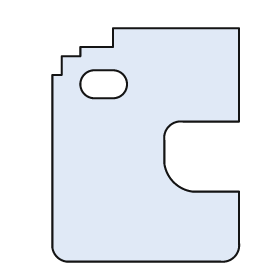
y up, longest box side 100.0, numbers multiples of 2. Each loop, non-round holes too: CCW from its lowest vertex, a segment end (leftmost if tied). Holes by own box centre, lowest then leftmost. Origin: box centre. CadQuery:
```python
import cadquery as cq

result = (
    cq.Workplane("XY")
    .moveTo(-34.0, -50.0)
    .lineTo(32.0, -50.0)
    .threePointArc((38.0, -48.0), (40.0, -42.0))
    .lineTo(40.0, -20.0)
    .lineTo(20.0, -20.0)
    .threePointArc((12.0, -16.0), (8.0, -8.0))
    .lineTo(8.0, 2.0)
    .threePointArc((10.0, 8.0), (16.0, 10.0))
    .lineTo(40.0, 10.0)
    .lineTo(40.0, 50.0)
    .lineTo(-14.0, 50.0)
    .lineTo(-14.0, 42.0)
    .lineTo(-28.0, 42.0)
    .lineTo(-28.0, 38.0)
    .lineTo(-36.0, 38.0)
    .lineTo(-36.0, 30.0)
    .lineTo(-40.0, 30.0)
    .lineTo(-40.0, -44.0)
    .threePointArc((-38.0, -48.0), (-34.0, -50.0))
    .close()
    .moveTo(-22.0, 20.0)
    .lineTo(-14.0, 20.0)
    .threePointArc((-8.0, 26.0), (-14.0, 32.0))
    .lineTo(-22.0, 32.0)
    .threePointArc((-28.0, 26.0), (-22.0, 20.0))
    .close()
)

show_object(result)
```